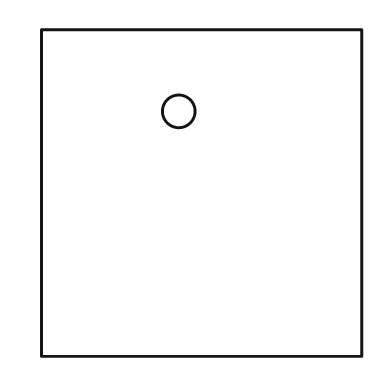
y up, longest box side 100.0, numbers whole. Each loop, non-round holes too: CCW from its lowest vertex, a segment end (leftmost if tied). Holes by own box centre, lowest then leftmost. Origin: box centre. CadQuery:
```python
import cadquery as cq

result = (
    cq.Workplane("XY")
    .moveTo(-49.0, -50.0)
    .lineTo(49.0, -50.0)
    .lineTo(49.0, 50.0)
    .lineTo(-49.0, 50.0)
    .close()
    .moveTo(-7.0, 25.0)
    .circle(5.0)
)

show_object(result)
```